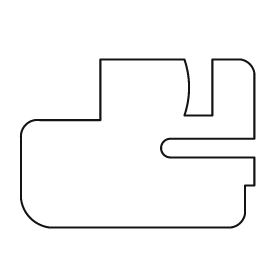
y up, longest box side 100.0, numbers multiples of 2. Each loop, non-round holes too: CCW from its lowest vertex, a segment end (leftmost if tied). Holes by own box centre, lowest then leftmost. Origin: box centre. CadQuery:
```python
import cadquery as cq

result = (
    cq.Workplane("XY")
    .moveTo(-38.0, -36.0)
    .lineTo(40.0, -36.0)
    .threePointArc((44.0, -34.0), (46.0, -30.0))
    .lineTo(46.0, -18.0)
    .lineTo(50.0, -18.0)
    .lineTo(50.0, -6.0)
    .lineTo(14.0, -6.0)
    .threePointArc((10.0, -2.0), (14.0, 2.0))
    .lineTo(50.0, 2.0)
    .lineTo(50.0, 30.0)
    .threePointArc((48.0, 34.0), (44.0, 36.0))
    .lineTo(32.0, 36.0)
    .lineTo(32.0, 12.0)
    .lineTo(20.0, 12.0)
    .threePointArc((22.0, 24.0), (20.0, 36.0))
    .lineTo(-16.0, 36.0)
    .lineTo(-16.0, 10.0)
    .lineTo(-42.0, 10.0)
    .threePointArc((-48.0, 8.0), (-50.0, 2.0))
    .lineTo(-50.0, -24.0)
    .threePointArc((-46.0, -32.0), (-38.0, -36.0))
    .close()
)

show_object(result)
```